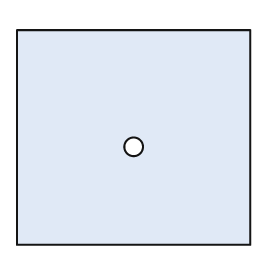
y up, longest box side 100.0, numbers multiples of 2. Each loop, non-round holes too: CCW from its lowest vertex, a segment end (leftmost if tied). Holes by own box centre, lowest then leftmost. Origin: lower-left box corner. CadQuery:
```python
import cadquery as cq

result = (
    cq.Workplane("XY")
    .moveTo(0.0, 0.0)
    .lineTo(100.0, 0.0)
    .lineTo(100.0, 92.0)
    .lineTo(0.0, 92.0)
    .close()
    .moveTo(50.0, 42.0)
    .circle(4.0)
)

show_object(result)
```